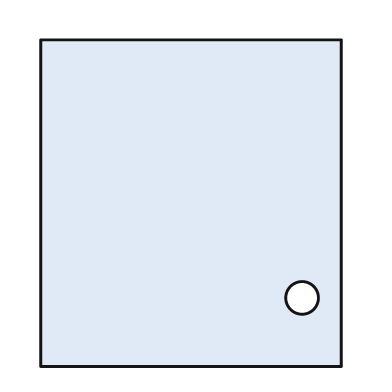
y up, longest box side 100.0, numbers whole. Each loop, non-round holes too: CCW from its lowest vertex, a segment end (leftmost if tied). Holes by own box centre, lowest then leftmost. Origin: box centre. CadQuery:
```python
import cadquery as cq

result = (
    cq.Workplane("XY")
    .moveTo(-46.0, -50.0)
    .lineTo(46.0, -50.0)
    .lineTo(46.0, 50.0)
    .lineTo(-46.0, 50.0)
    .close()
    .moveTo(34.0, -29.0)
    .circle(5.0)
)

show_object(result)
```